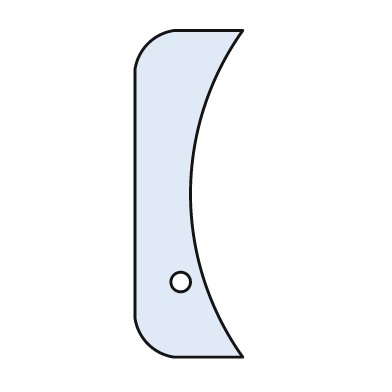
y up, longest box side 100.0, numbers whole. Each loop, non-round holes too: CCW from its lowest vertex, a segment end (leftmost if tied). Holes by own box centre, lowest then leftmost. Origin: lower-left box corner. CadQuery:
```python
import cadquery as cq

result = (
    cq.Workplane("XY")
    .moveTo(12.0, 0.0)
    .lineTo(33.0, 0.0)
    .threePointArc((17.0, 50.0), (33.0, 100.0))
    .lineTo(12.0, 100.0)
    .threePointArc((4.0, 96.0), (0.0, 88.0))
    .lineTo(0.0, 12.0)
    .threePointArc((4.0, 4.0), (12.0, 0.0))
    .close()
    .moveTo(14.0, 23.0)
    .circle(3.0)
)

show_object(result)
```